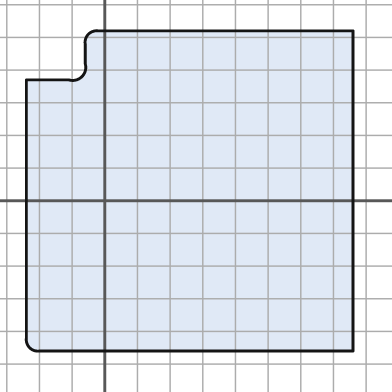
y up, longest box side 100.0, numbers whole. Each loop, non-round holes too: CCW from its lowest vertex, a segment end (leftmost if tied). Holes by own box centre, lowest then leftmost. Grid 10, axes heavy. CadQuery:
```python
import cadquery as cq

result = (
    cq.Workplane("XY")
    .moveTo(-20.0, -46.0)
    .lineTo(76.0, -46.0)
    .lineTo(76.0, 52.0)
    .lineTo(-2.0, 52.0)
    .threePointArc((-5.0, 51.0), (-6.0, 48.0))
    .lineTo(-6.0, 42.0)
    .threePointArc((-7.0, 38.0), (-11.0, 37.0))
    .lineTo(-24.0, 37.0)
    .lineTo(-24.0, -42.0)
    .threePointArc((-23.0, -45.0), (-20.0, -46.0))
    .close()
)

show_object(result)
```